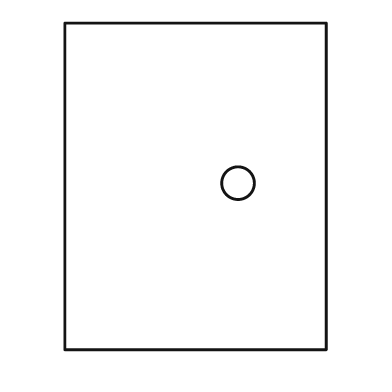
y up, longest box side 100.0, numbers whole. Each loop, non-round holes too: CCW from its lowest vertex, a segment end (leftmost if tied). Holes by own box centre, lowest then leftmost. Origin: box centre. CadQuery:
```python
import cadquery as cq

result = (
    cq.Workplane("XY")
    .moveTo(-40.0, -50.0)
    .lineTo(40.0, -50.0)
    .lineTo(40.0, 50.0)
    .lineTo(-40.0, 50.0)
    .close()
    .moveTo(13.0, 1.0)
    .circle(5.0)
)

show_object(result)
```